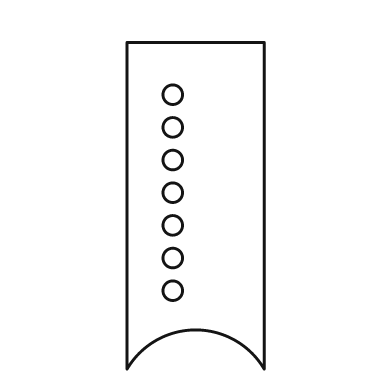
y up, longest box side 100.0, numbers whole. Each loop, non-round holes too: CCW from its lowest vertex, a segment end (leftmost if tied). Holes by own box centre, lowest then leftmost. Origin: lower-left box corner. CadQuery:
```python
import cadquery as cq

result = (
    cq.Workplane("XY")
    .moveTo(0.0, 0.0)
    .threePointArc((21.0, 12.0), (42.0, 0.0))
    .lineTo(42.0, 100.0)
    .lineTo(0.0, 100.0)
    .close()
    .moveTo(14.0, 24.0)
    .circle(3.0)
    .moveTo(14.0, 34.0)
    .circle(3.0)
    .moveTo(14.0, 44.0)
    .circle(3.0)
    .moveTo(14.0, 54.0)
    .circle(3.0)
    .moveTo(14.0, 64.0)
    .circle(3.0)
    .moveTo(14.0, 74.0)
    .circle(3.0)
    .moveTo(14.0, 84.0)
    .circle(3.0)
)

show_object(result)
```